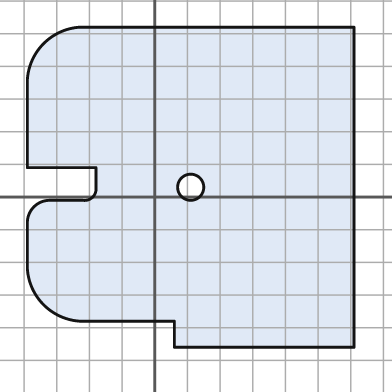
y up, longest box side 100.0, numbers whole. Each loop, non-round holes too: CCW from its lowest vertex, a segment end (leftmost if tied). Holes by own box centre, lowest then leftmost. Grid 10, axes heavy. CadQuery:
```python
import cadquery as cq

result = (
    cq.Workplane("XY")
    .moveTo(6.0, -46.0)
    .lineTo(61.0, -46.0)
    .lineTo(61.0, 52.0)
    .lineTo(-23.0, 52.0)
    .threePointArc((-34.0, 47.0), (-39.0, 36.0))
    .lineTo(-39.0, 9.0)
    .lineTo(-18.0, 9.0)
    .lineTo(-18.0, 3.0)
    .threePointArc((-19.0, 0.0), (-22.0, -1.0))
    .lineTo(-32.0, -1.0)
    .threePointArc((-37.0, -3.0), (-39.0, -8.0))
    .lineTo(-39.0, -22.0)
    .threePointArc((-34.0, -33.0), (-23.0, -38.0))
    .lineTo(6.0, -38.0)
    .close()
    .moveTo(11.0, 3.0)
    .circle(4.0)
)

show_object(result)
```